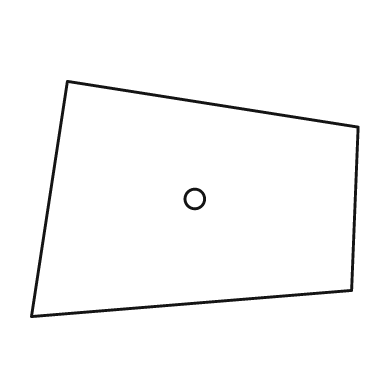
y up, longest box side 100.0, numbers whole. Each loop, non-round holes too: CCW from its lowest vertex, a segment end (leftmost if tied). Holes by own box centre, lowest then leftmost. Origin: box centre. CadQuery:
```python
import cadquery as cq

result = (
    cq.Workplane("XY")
    .moveTo(-50.0, -36.0)
    .lineTo(48.0, -28.0)
    .lineTo(50.0, 22.0)
    .lineTo(-39.0, 36.0)
    .close()
    .moveTo(0.0, 0.0)
    .circle(3.0)
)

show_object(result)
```